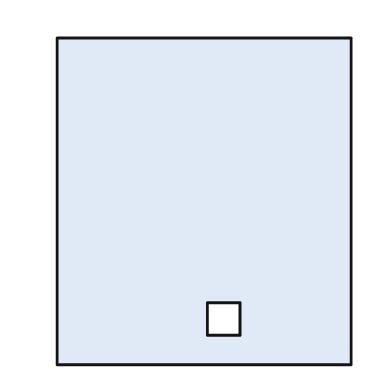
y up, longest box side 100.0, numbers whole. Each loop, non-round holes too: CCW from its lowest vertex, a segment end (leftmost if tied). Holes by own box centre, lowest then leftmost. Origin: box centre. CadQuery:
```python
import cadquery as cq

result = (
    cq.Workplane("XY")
    .moveTo(-45.0, -50.0)
    .lineTo(45.0, -50.0)
    .lineTo(45.0, 50.0)
    .lineTo(-45.0, 50.0)
    .close()
    .moveTo(1.0, -41.0)
    .lineTo(11.0, -41.0)
    .lineTo(11.0, -31.0)
    .lineTo(1.0, -31.0)
    .close()
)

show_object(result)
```